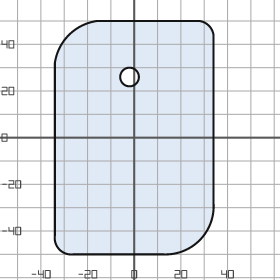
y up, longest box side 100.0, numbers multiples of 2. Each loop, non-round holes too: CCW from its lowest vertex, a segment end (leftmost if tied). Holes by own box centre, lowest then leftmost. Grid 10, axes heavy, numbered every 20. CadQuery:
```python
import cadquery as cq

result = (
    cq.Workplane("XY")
    .moveTo(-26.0, -50.0)
    .lineTo(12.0, -50.0)
    .threePointArc((28.0, -44.0), (34.0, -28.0))
    .lineTo(34.0, 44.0)
    .threePointArc((32.0, 48.0), (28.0, 50.0))
    .lineTo(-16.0, 50.0)
    .threePointArc((-28.0, 44.0), (-34.0, 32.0))
    .lineTo(-34.0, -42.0)
    .threePointArc((-32.0, -48.0), (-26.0, -50.0))
    .close()
    .moveTo(-2.0, 26.0)
    .circle(4.0)
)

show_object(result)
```